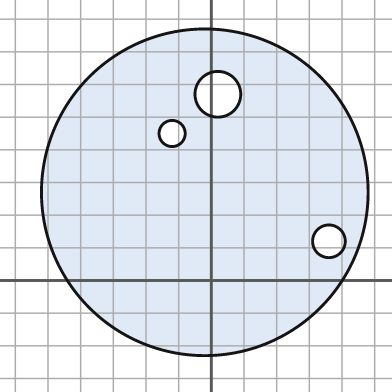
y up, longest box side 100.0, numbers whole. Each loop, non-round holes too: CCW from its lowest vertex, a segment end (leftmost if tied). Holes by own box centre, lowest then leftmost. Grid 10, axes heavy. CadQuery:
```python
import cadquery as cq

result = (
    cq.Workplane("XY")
    .moveTo(-2.0, 27.0)
    .circle(50.0)
    .moveTo(36.0, 12.0)
    .circle(5.0)
    .moveTo(-12.0, 45.0)
    .circle(4.0)
    .moveTo(2.0, 57.0)
    .circle(7.0)
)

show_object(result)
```